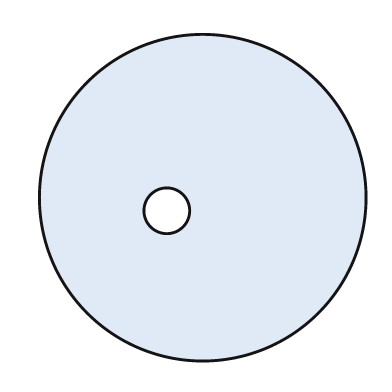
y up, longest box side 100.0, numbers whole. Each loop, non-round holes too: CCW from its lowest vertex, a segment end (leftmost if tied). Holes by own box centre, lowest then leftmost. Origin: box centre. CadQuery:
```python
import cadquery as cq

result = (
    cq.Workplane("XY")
    .moveTo(0.0, 0.0)
    .circle(50.0)
    .moveTo(-11.0, -4.0)
    .circle(7.0)
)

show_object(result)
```